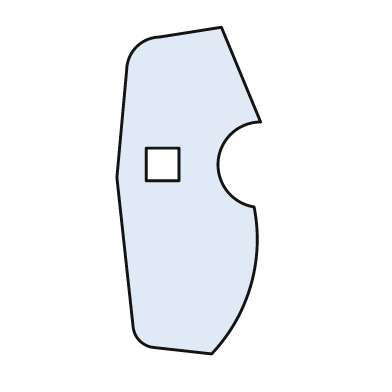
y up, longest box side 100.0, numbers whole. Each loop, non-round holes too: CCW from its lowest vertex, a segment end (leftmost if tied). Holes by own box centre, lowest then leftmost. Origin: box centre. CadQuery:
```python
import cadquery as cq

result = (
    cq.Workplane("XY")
    .moveTo(7.0, -50.0)
    .threePointArc((19.0, -29.0), (20.0, -5.0))
    .threePointArc((9.0, 9.0), (22.0, 21.0))
    .lineTo(10.0, 50.0)
    .lineTo(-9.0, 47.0)
    .threePointArc((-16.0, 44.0), (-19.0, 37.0))
    .lineTo(-22.0, 4.0)
    .lineTo(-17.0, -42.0)
    .threePointArc((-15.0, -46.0), (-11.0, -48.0))
    .close()
    .moveTo(-13.0, 3.0)
    .lineTo(-3.0, 3.0)
    .lineTo(-3.0, 13.0)
    .lineTo(-13.0, 13.0)
    .close()
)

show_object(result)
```